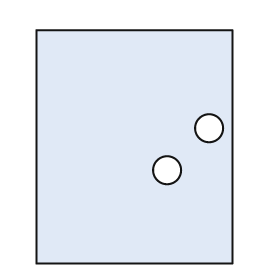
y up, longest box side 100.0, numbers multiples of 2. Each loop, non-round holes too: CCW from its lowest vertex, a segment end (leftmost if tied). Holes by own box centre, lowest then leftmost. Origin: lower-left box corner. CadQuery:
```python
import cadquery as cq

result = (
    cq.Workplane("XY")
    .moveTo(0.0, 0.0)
    .lineTo(84.0, 0.0)
    .lineTo(84.0, 100.0)
    .lineTo(0.0, 100.0)
    .close()
    .moveTo(56.0, 40.0)
    .circle(6.0)
    .moveTo(74.0, 58.0)
    .circle(6.0)
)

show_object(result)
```